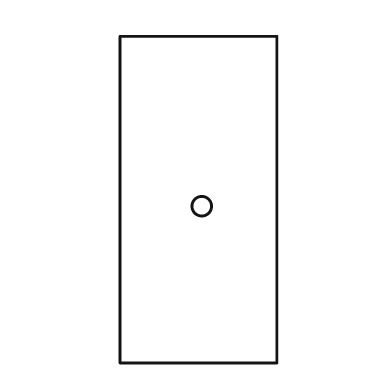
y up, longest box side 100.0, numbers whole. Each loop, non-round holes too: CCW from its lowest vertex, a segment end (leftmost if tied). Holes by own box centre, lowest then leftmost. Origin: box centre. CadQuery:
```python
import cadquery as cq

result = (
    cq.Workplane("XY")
    .moveTo(-24.0, -50.0)
    .lineTo(24.0, -50.0)
    .lineTo(24.0, 50.0)
    .lineTo(-24.0, 50.0)
    .close()
    .moveTo(1.0, -2.0)
    .circle(3.0)
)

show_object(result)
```